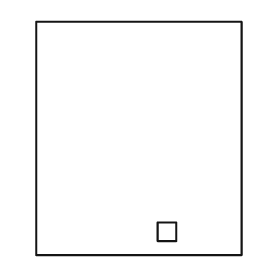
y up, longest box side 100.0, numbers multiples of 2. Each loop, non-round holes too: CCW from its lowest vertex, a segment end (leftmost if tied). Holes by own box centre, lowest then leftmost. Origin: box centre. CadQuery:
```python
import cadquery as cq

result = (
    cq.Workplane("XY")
    .moveTo(-44.0, -50.0)
    .lineTo(44.0, -50.0)
    .lineTo(44.0, 50.0)
    .lineTo(-44.0, 50.0)
    .close()
    .moveTo(8.0, -44.0)
    .lineTo(16.0, -44.0)
    .lineTo(16.0, -36.0)
    .lineTo(8.0, -36.0)
    .close()
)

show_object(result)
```